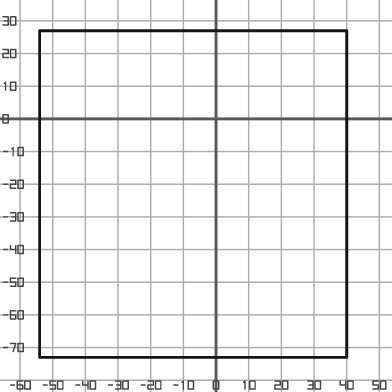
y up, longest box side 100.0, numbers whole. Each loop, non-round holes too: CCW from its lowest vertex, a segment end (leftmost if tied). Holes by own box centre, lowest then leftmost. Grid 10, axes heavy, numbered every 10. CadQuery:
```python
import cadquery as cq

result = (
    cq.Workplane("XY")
    .moveTo(-54.0, -73.0)
    .lineTo(40.0, -73.0)
    .lineTo(40.0, 27.0)
    .lineTo(-54.0, 27.0)
    .close()
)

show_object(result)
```